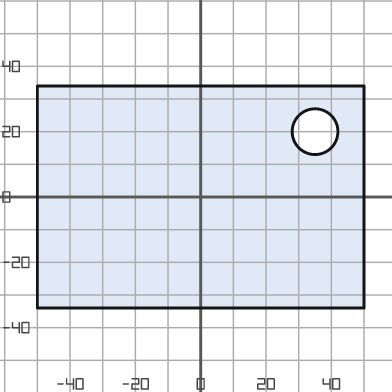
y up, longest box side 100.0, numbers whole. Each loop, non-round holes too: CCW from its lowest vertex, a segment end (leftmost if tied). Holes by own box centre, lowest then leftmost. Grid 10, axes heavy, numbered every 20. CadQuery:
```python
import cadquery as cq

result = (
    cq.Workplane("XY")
    .moveTo(-50.0, -34.0)
    .lineTo(50.0, -34.0)
    .lineTo(50.0, 34.0)
    .lineTo(-50.0, 34.0)
    .close()
    .moveTo(35.0, 20.0)
    .circle(7.0)
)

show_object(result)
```